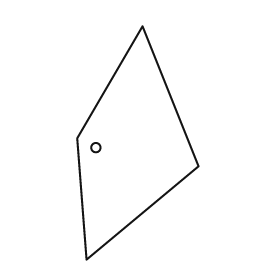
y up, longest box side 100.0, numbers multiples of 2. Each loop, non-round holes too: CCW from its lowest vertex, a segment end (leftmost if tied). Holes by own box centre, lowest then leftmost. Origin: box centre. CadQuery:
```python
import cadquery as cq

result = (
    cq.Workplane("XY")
    .moveTo(-22.0, -50.0)
    .lineTo(26.0, -10.0)
    .lineTo(2.0, 50.0)
    .lineTo(-26.0, 2.0)
    .close()
    .moveTo(-18.0, -2.0)
    .circle(2.0)
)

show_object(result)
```